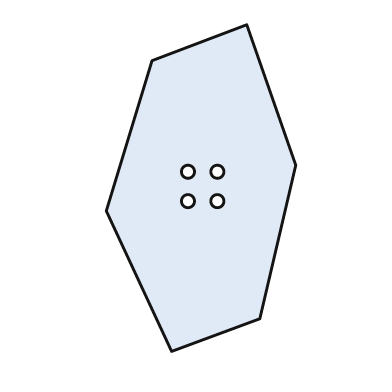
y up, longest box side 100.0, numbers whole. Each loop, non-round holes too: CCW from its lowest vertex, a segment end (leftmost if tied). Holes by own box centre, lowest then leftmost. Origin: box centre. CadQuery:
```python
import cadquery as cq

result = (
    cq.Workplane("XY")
    .moveTo(-9.0, -50.0)
    .lineTo(18.0, -40.0)
    .lineTo(29.0, 7.0)
    .lineTo(14.0, 50.0)
    .lineTo(-15.0, 39.0)
    .lineTo(-29.0, -7.0)
    .close()
    .moveTo(-4.0, -4.0)
    .circle(2.0)
    .moveTo(5.0, -4.0)
    .circle(2.0)
    .moveTo(-4.0, 5.0)
    .circle(2.0)
    .moveTo(5.0, 5.0)
    .circle(2.0)
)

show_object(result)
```